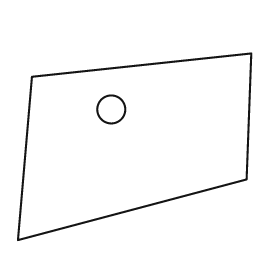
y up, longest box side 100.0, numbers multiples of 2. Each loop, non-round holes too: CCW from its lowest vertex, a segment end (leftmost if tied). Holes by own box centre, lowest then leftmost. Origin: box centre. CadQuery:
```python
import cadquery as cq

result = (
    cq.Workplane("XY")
    .moveTo(-50.0, -40.0)
    .lineTo(48.0, -14.0)
    .lineTo(50.0, 40.0)
    .lineTo(-44.0, 30.0)
    .close()
    .moveTo(-10.0, 16.0)
    .circle(6.0)
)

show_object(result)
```